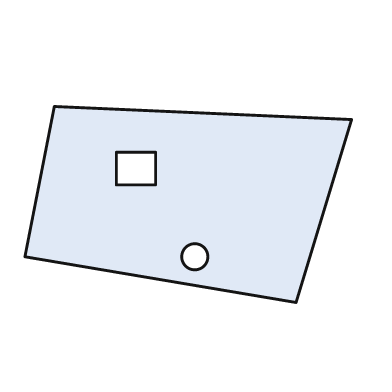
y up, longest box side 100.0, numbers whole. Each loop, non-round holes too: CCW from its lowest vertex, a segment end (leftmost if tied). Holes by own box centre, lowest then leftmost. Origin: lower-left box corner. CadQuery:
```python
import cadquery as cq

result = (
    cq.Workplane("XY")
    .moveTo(83.0, 0.0)
    .lineTo(100.0, 56.0)
    .lineTo(9.0, 60.0)
    .lineTo(0.0, 14.0)
    .close()
    .moveTo(52.0, 14.0)
    .circle(4.0)
    .moveTo(28.0, 36.0)
    .lineTo(40.0, 36.0)
    .lineTo(40.0, 46.0)
    .lineTo(28.0, 46.0)
    .close()
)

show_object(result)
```